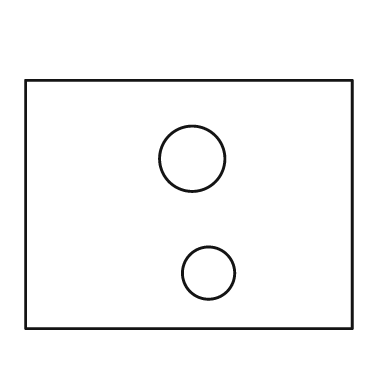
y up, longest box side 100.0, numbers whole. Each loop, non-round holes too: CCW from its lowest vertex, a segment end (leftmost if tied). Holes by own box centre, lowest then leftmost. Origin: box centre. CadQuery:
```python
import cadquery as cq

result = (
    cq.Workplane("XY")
    .moveTo(-50.0, -38.0)
    .lineTo(50.0, -38.0)
    .lineTo(50.0, 38.0)
    .lineTo(-50.0, 38.0)
    .close()
    .moveTo(6.0, -21.0)
    .circle(8.0)
    .moveTo(1.0, 14.0)
    .circle(10.0)
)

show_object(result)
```